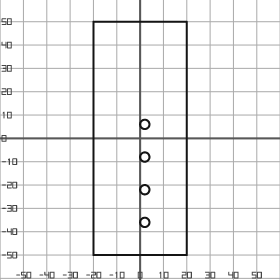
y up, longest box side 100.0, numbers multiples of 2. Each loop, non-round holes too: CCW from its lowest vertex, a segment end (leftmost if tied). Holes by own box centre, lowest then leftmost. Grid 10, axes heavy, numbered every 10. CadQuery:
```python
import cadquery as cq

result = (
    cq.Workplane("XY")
    .moveTo(-20.0, -50.0)
    .lineTo(20.0, -50.0)
    .lineTo(20.0, 50.0)
    .lineTo(-20.0, 50.0)
    .close()
    .moveTo(2.0, -36.0)
    .circle(2.0)
    .moveTo(2.0, -22.0)
    .circle(2.0)
    .moveTo(2.0, -8.0)
    .circle(2.0)
    .moveTo(2.0, 6.0)
    .circle(2.0)
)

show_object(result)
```